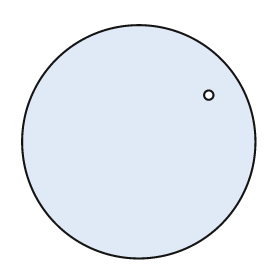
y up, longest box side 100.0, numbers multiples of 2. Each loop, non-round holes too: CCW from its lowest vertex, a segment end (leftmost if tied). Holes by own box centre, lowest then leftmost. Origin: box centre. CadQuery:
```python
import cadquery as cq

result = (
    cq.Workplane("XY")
    .moveTo(0.0, 0.0)
    .circle(50.0)
    .moveTo(30.0, 20.0)
    .circle(2.0)
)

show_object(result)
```